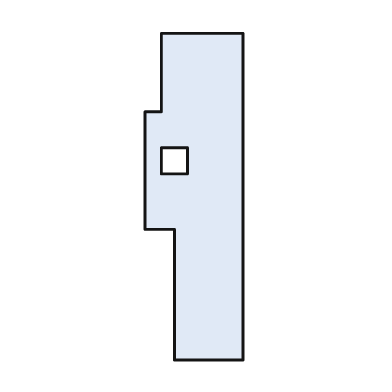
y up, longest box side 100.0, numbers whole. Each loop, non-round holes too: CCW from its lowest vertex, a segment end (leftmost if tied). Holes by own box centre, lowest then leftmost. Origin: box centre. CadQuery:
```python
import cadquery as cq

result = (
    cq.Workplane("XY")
    .moveTo(-6.0, -50.0)
    .lineTo(15.0, -50.0)
    .lineTo(15.0, 50.0)
    .lineTo(-10.0, 50.0)
    .lineTo(-10.0, 26.0)
    .lineTo(-15.0, 26.0)
    .lineTo(-15.0, -10.0)
    .lineTo(-6.0, -10.0)
    .close()
    .moveTo(-10.0, 7.0)
    .lineTo(-2.0, 7.0)
    .lineTo(-2.0, 15.0)
    .lineTo(-10.0, 15.0)
    .close()
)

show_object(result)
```